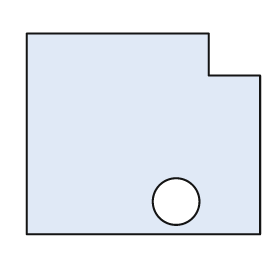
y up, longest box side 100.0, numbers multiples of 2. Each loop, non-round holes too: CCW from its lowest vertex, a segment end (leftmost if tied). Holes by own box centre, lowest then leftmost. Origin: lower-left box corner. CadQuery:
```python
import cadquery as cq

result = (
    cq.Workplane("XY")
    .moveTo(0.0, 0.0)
    .lineTo(100.0, 0.0)
    .lineTo(100.0, 68.0)
    .lineTo(78.0, 68.0)
    .lineTo(78.0, 86.0)
    .lineTo(0.0, 86.0)
    .close()
    .moveTo(64.0, 14.0)
    .circle(10.0)
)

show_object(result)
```